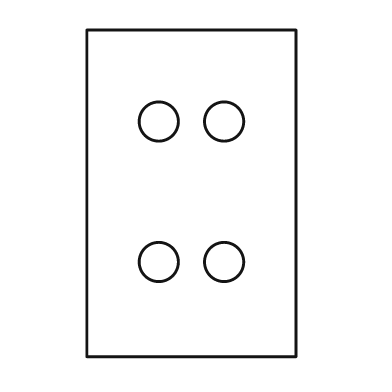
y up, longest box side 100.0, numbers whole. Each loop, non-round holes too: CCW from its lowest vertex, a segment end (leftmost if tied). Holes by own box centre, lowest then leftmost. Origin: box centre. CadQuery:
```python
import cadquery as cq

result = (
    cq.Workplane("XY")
    .moveTo(-32.0, -50.0)
    .lineTo(32.0, -50.0)
    .lineTo(32.0, 50.0)
    .lineTo(-32.0, 50.0)
    .close()
    .moveTo(-10.0, -21.0)
    .circle(6.0)
    .moveTo(10.0, -21.0)
    .circle(6.0)
    .moveTo(-10.0, 22.0)
    .circle(6.0)
    .moveTo(10.0, 22.0)
    .circle(6.0)
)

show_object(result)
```